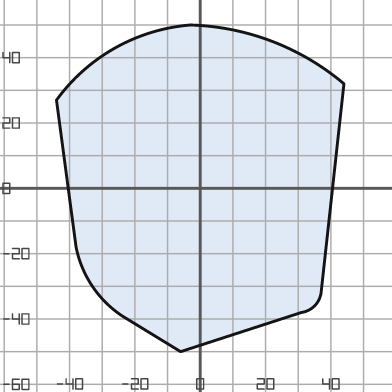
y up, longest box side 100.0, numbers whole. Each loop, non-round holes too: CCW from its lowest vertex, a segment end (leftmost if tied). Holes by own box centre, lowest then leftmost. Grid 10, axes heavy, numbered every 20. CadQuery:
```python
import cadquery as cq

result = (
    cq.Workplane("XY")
    .moveTo(-6.0, -50.0)
    .lineTo(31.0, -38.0)
    .threePointArc((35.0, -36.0), (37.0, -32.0))
    .lineTo(44.0, 32.0)
    .threePointArc((22.0, 45.0), (-3.0, 50.0))
    .threePointArc((-26.0, 43.0), (-44.0, 27.0))
    .lineTo(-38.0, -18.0)
    .threePointArc((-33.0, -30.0), (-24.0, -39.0))
    .close()
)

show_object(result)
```